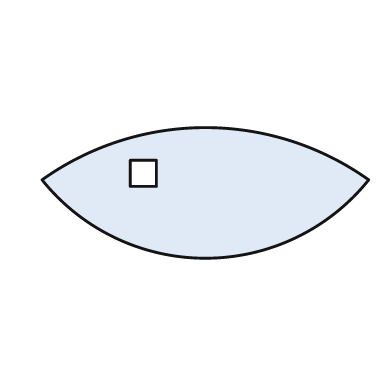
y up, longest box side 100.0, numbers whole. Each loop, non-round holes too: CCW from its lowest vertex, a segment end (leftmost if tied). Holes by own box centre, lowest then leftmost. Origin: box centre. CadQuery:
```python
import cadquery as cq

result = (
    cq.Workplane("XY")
    .moveTo(-50.0, 4.0)
    .threePointArc((0.0, -20.0), (50.0, 4.0))
    .threePointArc((0.0, 20.0), (-50.0, 4.0))
    .close()
    .moveTo(-23.0, 2.0)
    .lineTo(-15.0, 2.0)
    .lineTo(-15.0, 10.0)
    .lineTo(-23.0, 10.0)
    .close()
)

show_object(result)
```